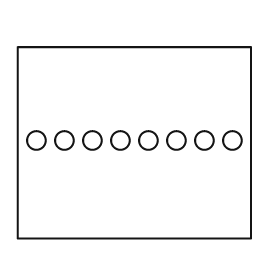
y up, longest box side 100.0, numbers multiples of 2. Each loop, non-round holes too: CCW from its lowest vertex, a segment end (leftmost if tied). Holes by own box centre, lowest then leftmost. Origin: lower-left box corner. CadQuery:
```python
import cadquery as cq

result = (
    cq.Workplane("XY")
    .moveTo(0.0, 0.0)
    .lineTo(100.0, 0.0)
    .lineTo(100.0, 82.0)
    .lineTo(0.0, 82.0)
    .close()
    .moveTo(8.0, 42.0)
    .circle(4.0)
    .moveTo(20.0, 42.0)
    .circle(4.0)
    .moveTo(32.0, 42.0)
    .circle(4.0)
    .moveTo(44.0, 42.0)
    .circle(4.0)
    .moveTo(56.0, 42.0)
    .circle(4.0)
    .moveTo(68.0, 42.0)
    .circle(4.0)
    .moveTo(80.0, 42.0)
    .circle(4.0)
    .moveTo(92.0, 42.0)
    .circle(4.0)
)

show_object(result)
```